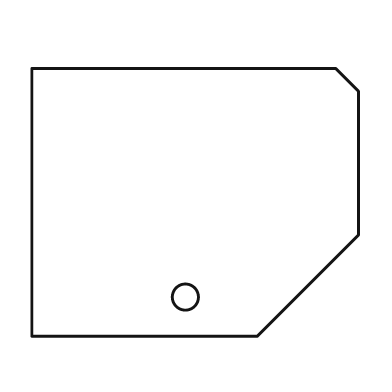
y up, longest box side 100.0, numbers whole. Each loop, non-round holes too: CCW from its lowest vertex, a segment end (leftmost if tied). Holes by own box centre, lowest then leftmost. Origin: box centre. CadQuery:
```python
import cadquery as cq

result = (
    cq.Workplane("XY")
    .moveTo(-50.0, -41.0)
    .lineTo(19.0, -41.0)
    .lineTo(50.0, -10.0)
    .lineTo(50.0, 34.0)
    .lineTo(43.0, 41.0)
    .lineTo(-50.0, 41.0)
    .close()
    .moveTo(-3.0, -29.0)
    .circle(4.0)
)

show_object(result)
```